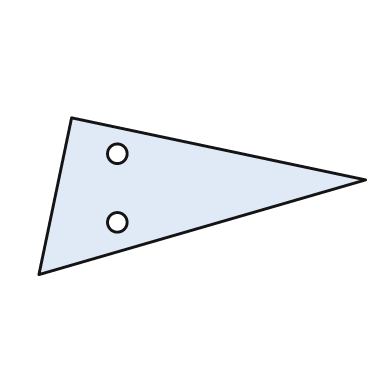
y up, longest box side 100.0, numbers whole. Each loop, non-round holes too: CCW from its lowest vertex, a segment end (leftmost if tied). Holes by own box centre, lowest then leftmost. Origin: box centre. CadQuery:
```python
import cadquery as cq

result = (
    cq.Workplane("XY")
    .moveTo(-50.0, -24.0)
    .lineTo(50.0, 5.0)
    .lineTo(-40.0, 24.0)
    .close()
    .moveTo(-26.0, -8.0)
    .circle(3.0)
    .moveTo(-26.0, 13.0)
    .circle(3.0)
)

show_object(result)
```